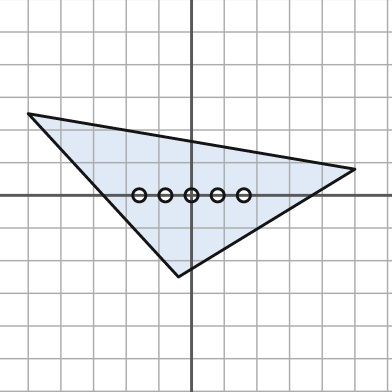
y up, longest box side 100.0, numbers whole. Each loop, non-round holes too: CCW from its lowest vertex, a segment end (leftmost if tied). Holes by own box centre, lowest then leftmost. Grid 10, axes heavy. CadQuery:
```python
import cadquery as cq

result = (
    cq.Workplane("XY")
    .moveTo(-4.0, -25.0)
    .lineTo(50.0, 8.0)
    .lineTo(-50.0, 25.0)
    .close()
    .moveTo(-16.0, 0.0)
    .circle(2.0)
    .moveTo(-8.0, 0.0)
    .circle(2.0)
    .moveTo(0.0, 0.0)
    .circle(2.0)
    .moveTo(8.0, 0.0)
    .circle(2.0)
    .moveTo(16.0, 0.0)
    .circle(2.0)
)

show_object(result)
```